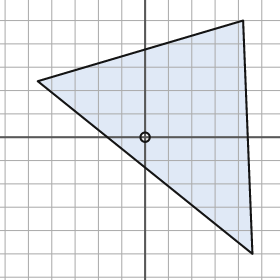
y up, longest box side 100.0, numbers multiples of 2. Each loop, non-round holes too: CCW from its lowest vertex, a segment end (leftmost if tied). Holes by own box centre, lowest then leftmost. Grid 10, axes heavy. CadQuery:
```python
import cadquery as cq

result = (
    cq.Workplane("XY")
    .moveTo(46.0, -50.0)
    .lineTo(42.0, 50.0)
    .lineTo(-46.0, 24.0)
    .close()
    .moveTo(0.0, 0.0)
    .circle(2.0)
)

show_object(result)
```